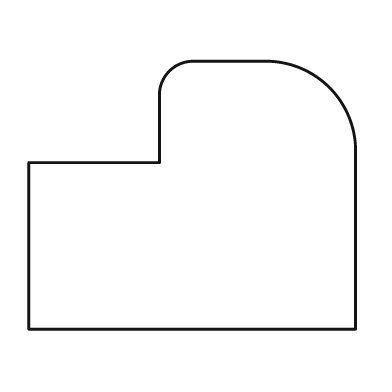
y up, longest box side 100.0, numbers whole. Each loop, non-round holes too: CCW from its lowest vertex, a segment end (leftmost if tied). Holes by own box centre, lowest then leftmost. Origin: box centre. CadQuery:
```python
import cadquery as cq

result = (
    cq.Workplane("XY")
    .moveTo(-50.0, -41.0)
    .lineTo(50.0, -41.0)
    .lineTo(50.0, 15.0)
    .threePointArc((42.0, 33.0), (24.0, 41.0))
    .lineTo(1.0, 41.0)
    .threePointArc((-7.0, 38.0), (-10.0, 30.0))
    .lineTo(-10.0, 10.0)
    .lineTo(-50.0, 10.0)
    .close()
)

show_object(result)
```